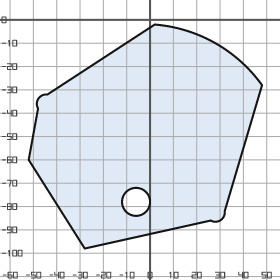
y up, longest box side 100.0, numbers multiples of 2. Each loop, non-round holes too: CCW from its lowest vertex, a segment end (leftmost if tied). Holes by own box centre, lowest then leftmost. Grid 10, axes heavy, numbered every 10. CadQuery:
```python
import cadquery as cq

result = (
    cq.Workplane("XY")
    .moveTo(-28.0, -98.0)
    .lineTo(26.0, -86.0)
    .threePointArc((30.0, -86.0), (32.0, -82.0))
    .lineTo(48.0, -28.0)
    .threePointArc((28.0, -10.0), (2.0, -2.0))
    .lineTo(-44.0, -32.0)
    .threePointArc((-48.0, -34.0), (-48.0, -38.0))
    .lineTo(-52.0, -60.0)
    .close()
    .moveTo(-6.0, -78.0)
    .circle(6.0)
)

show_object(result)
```